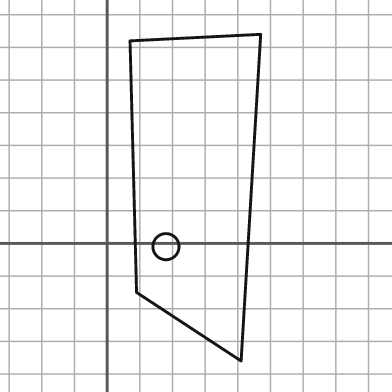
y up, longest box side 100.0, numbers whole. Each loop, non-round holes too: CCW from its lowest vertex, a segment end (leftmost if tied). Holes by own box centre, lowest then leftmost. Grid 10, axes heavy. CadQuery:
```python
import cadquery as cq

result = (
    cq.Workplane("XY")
    .moveTo(41.0, -36.0)
    .lineTo(47.0, 64.0)
    .lineTo(7.0, 62.0)
    .lineTo(9.0, -15.0)
    .close()
    .moveTo(18.0, -1.0)
    .circle(4.0)
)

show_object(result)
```